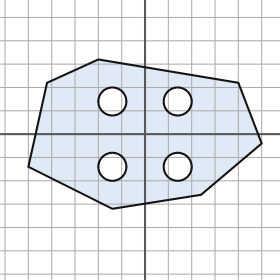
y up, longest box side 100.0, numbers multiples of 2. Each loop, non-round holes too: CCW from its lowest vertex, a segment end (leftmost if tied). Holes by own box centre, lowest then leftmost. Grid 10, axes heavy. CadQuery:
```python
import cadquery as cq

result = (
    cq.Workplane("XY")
    .moveTo(-14.0, -32.0)
    .lineTo(24.0, -26.0)
    .lineTo(50.0, -4.0)
    .lineTo(40.0, 22.0)
    .lineTo(-20.0, 32.0)
    .lineTo(-42.0, 22.0)
    .lineTo(-50.0, -14.0)
    .close()
    .moveTo(-14.0, -14.0)
    .circle(6.0)
    .moveTo(14.0, -14.0)
    .circle(6.0)
    .moveTo(-14.0, 14.0)
    .circle(6.0)
    .moveTo(14.0, 14.0)
    .circle(6.0)
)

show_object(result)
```